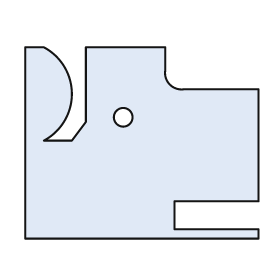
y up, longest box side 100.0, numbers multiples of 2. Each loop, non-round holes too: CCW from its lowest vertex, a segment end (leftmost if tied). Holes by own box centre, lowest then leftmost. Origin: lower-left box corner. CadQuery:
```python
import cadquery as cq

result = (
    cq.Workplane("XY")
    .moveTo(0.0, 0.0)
    .lineTo(100.0, 0.0)
    .lineTo(100.0, 4.0)
    .lineTo(64.0, 4.0)
    .lineTo(64.0, 16.0)
    .lineTo(100.0, 16.0)
    .lineTo(100.0, 64.0)
    .lineTo(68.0, 64.0)
    .threePointArc((62.0, 66.0), (60.0, 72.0))
    .lineTo(60.0, 82.0)
    .lineTo(26.0, 82.0)
    .lineTo(26.0, 50.0)
    .lineTo(20.0, 42.0)
    .lineTo(8.0, 42.0)
    .threePointArc((20.0, 62.0), (8.0, 82.0))
    .lineTo(0.0, 82.0)
    .close()
    .moveTo(42.0, 52.0)
    .circle(4.0)
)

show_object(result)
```